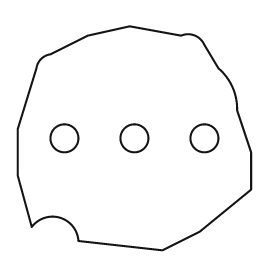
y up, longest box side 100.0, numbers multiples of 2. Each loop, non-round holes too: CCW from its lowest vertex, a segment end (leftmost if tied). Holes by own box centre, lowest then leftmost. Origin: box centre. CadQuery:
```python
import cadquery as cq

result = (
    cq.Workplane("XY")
    .moveTo(12.0, -48.0)
    .lineTo(28.0, -40.0)
    .lineTo(50.0, -22.0)
    .lineTo(50.0, -6.0)
    .lineTo(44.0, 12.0)
    .threePointArc((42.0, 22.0), (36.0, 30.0))
    .lineTo(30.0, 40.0)
    .threePointArc((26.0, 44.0), (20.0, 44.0))
    .lineTo(-2.0, 48.0)
    .lineTo(-20.0, 44.0)
    .lineTo(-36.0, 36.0)
    .threePointArc((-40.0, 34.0), (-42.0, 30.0))
    .lineTo(-50.0, 4.0)
    .lineTo(-50.0, -16.0)
    .lineTo(-44.0, -38.0)
    .threePointArc((-32.0, -34.0), (-24.0, -44.0))
    .close()
    .moveTo(-30.0, 0.0)
    .circle(6.0)
    .moveTo(0.0, 0.0)
    .circle(6.0)
    .moveTo(30.0, 0.0)
    .circle(6.0)
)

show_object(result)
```